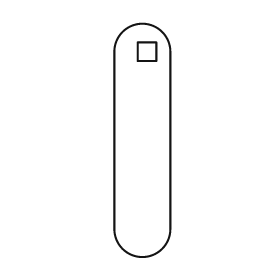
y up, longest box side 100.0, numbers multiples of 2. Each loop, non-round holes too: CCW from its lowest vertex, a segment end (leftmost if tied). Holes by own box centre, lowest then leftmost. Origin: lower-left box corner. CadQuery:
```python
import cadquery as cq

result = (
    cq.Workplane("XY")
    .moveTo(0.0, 12.0)
    .threePointArc((12.0, 0.0), (24.0, 12.0))
    .lineTo(24.0, 88.0)
    .threePointArc((12.0, 100.0), (0.0, 88.0))
    .close()
    .moveTo(10.0, 84.0)
    .lineTo(18.0, 84.0)
    .lineTo(18.0, 92.0)
    .lineTo(10.0, 92.0)
    .close()
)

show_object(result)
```